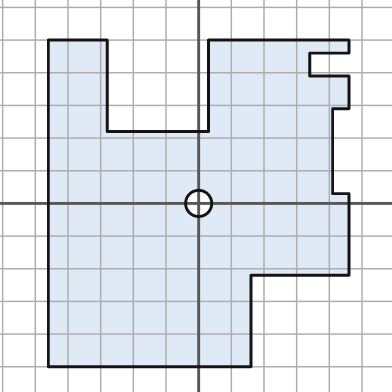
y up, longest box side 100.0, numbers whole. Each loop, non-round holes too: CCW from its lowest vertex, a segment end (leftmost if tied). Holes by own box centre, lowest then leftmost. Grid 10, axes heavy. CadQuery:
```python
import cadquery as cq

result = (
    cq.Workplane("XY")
    .moveTo(-46.0, -50.0)
    .lineTo(16.0, -50.0)
    .lineTo(16.0, -22.0)
    .lineTo(46.0, -22.0)
    .lineTo(46.0, 3.0)
    .lineTo(41.0, 3.0)
    .lineTo(41.0, 29.0)
    .lineTo(46.0, 29.0)
    .lineTo(46.0, 39.0)
    .lineTo(34.0, 39.0)
    .lineTo(34.0, 46.0)
    .lineTo(46.0, 46.0)
    .lineTo(46.0, 50.0)
    .lineTo(3.0, 50.0)
    .lineTo(3.0, 22.0)
    .lineTo(-28.0, 22.0)
    .lineTo(-28.0, 50.0)
    .lineTo(-46.0, 50.0)
    .close()
    .moveTo(0.0, 0.0)
    .circle(4.0)
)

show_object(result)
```